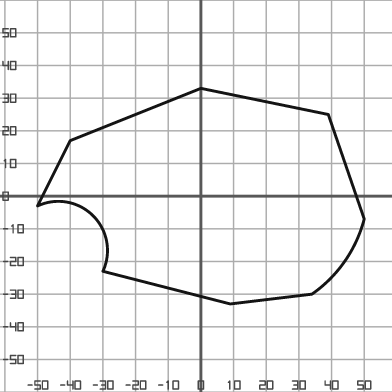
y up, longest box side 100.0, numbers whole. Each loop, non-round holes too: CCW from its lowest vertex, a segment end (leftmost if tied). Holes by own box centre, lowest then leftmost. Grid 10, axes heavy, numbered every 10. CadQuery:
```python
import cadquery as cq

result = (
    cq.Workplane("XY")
    .moveTo(9.0, -33.0)
    .lineTo(34.0, -30.0)
    .threePointArc((44.0, -20.0), (50.0, -7.0))
    .lineTo(39.0, 25.0)
    .lineTo(0.0, 33.0)
    .lineTo(-40.0, 17.0)
    .lineTo(-50.0, -3.0)
    .threePointArc((-33.0, -6.0), (-30.0, -23.0))
    .close()
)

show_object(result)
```